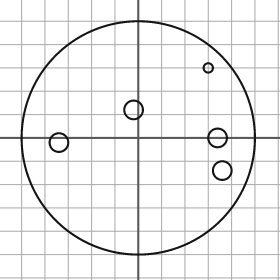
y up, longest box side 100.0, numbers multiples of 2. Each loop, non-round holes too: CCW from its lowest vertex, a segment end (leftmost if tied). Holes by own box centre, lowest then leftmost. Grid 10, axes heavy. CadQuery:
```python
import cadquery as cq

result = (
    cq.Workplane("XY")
    .moveTo(0.0, 0.0)
    .circle(50.0)
    .moveTo(36.0, -14.0)
    .circle(4.0)
    .moveTo(-34.0, -2.0)
    .circle(4.0)
    .moveTo(34.0, 0.0)
    .circle(4.0)
    .moveTo(-2.0, 12.0)
    .circle(4.0)
    .moveTo(30.0, 30.0)
    .circle(2.0)
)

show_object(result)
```